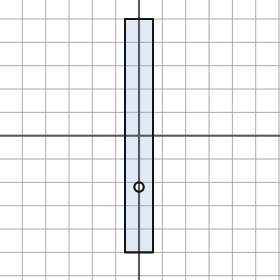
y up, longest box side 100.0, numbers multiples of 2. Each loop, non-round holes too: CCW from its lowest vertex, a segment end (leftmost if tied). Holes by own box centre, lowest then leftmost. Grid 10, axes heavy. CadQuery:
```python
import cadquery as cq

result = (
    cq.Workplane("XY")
    .moveTo(-6.0, -50.0)
    .lineTo(6.0, -50.0)
    .lineTo(6.0, 50.0)
    .lineTo(-6.0, 50.0)
    .close()
    .moveTo(0.0, -22.0)
    .circle(2.0)
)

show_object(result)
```